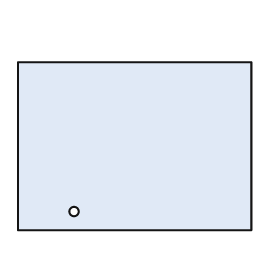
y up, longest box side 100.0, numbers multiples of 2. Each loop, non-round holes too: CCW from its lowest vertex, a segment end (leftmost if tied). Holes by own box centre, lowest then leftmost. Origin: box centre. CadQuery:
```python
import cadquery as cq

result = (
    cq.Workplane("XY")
    .moveTo(-50.0, -36.0)
    .lineTo(50.0, -36.0)
    .lineTo(50.0, 36.0)
    .lineTo(-50.0, 36.0)
    .close()
    .moveTo(-26.0, -28.0)
    .circle(2.0)
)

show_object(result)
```